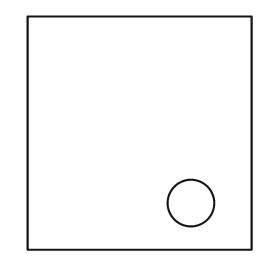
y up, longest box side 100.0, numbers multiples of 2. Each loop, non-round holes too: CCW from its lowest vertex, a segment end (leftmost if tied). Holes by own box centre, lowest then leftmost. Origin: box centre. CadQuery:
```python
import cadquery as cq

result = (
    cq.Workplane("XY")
    .moveTo(-48.0, -50.0)
    .lineTo(48.0, -50.0)
    .lineTo(48.0, 50.0)
    .lineTo(-48.0, 50.0)
    .close()
    .moveTo(22.0, -30.0)
    .circle(10.0)
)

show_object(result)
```